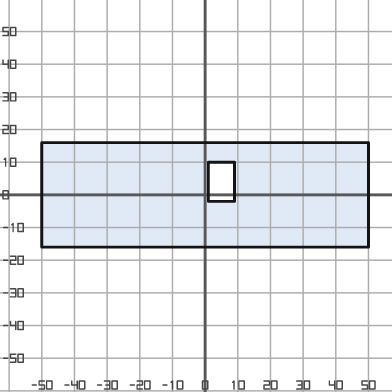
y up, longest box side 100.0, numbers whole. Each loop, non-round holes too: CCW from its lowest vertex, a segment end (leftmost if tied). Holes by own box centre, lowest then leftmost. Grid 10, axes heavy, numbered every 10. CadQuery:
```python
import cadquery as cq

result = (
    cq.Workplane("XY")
    .moveTo(-50.0, -16.0)
    .lineTo(50.0, -16.0)
    .lineTo(50.0, 16.0)
    .lineTo(-50.0, 16.0)
    .close()
    .moveTo(1.0, -2.0)
    .lineTo(9.0, -2.0)
    .lineTo(9.0, 10.0)
    .lineTo(1.0, 10.0)
    .close()
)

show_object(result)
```